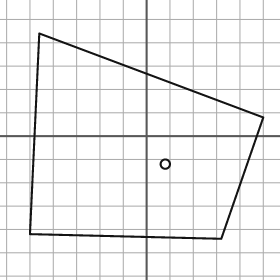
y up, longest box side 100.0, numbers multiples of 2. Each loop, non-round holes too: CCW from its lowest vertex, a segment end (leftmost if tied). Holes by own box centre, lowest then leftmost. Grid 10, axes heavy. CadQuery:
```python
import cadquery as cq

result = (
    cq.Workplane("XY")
    .moveTo(32.0, -44.0)
    .lineTo(50.0, 8.0)
    .lineTo(-46.0, 44.0)
    .lineTo(-50.0, -42.0)
    .close()
    .moveTo(8.0, -12.0)
    .circle(2.0)
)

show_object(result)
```